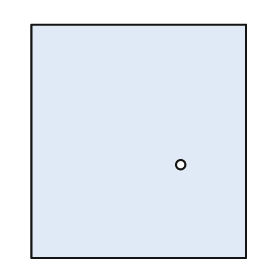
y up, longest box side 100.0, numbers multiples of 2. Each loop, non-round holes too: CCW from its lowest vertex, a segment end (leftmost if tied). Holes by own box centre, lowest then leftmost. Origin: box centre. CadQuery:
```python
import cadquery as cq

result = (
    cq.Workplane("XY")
    .moveTo(-46.0, -50.0)
    .lineTo(46.0, -50.0)
    .lineTo(46.0, 50.0)
    .lineTo(-46.0, 50.0)
    .close()
    .moveTo(18.0, -10.0)
    .circle(2.0)
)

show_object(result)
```